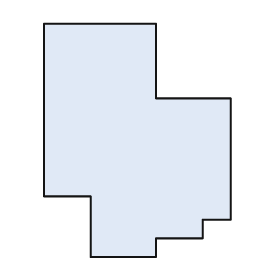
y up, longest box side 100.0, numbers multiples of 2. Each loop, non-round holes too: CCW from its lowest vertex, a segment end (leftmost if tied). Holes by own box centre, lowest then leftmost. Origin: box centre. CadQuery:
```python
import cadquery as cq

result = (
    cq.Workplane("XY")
    .moveTo(-20.0, -50.0)
    .lineTo(8.0, -50.0)
    .lineTo(8.0, -42.0)
    .lineTo(28.0, -42.0)
    .lineTo(28.0, -34.0)
    .lineTo(40.0, -34.0)
    .lineTo(40.0, 18.0)
    .lineTo(8.0, 18.0)
    .lineTo(8.0, 50.0)
    .lineTo(-40.0, 50.0)
    .lineTo(-40.0, -24.0)
    .lineTo(-20.0, -24.0)
    .close()
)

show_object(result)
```